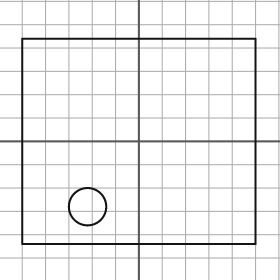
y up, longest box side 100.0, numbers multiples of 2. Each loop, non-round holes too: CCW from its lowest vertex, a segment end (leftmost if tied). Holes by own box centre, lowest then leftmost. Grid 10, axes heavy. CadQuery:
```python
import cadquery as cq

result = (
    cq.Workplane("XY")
    .moveTo(-50.0, -44.0)
    .lineTo(50.0, -44.0)
    .lineTo(50.0, 44.0)
    .lineTo(-50.0, 44.0)
    .close()
    .moveTo(-22.0, -28.0)
    .circle(8.0)
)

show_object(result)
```